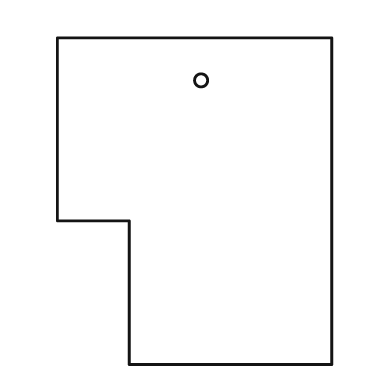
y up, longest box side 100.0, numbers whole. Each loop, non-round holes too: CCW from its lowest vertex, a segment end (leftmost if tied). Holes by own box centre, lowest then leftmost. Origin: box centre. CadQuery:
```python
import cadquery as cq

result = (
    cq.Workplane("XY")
    .moveTo(-20.0, -50.0)
    .lineTo(42.0, -50.0)
    .lineTo(42.0, 50.0)
    .lineTo(-42.0, 50.0)
    .lineTo(-42.0, -6.0)
    .lineTo(-20.0, -6.0)
    .close()
    .moveTo(2.0, 37.0)
    .circle(2.0)
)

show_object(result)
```